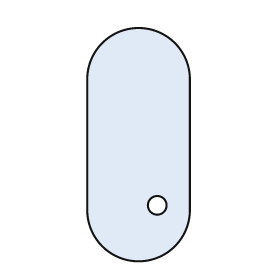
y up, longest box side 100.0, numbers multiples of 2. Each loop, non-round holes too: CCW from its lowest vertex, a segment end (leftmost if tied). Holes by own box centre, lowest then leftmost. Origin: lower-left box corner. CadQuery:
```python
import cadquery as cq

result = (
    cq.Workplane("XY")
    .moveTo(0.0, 22.0)
    .threePointArc((22.0, 0.0), (44.0, 22.0))
    .lineTo(44.0, 78.0)
    .threePointArc((22.0, 100.0), (0.0, 78.0))
    .close()
    .moveTo(30.0, 24.0)
    .circle(4.0)
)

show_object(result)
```